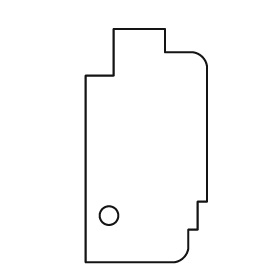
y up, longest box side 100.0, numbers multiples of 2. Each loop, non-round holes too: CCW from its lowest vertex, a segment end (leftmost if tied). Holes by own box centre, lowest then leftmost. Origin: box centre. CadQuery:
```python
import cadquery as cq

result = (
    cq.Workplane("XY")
    .moveTo(-26.0, -50.0)
    .lineTo(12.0, -50.0)
    .threePointArc((16.0, -48.0), (18.0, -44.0))
    .lineTo(18.0, -36.0)
    .lineTo(22.0, -36.0)
    .lineTo(22.0, -24.0)
    .lineTo(26.0, -24.0)
    .lineTo(26.0, 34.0)
    .threePointArc((24.0, 38.0), (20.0, 40.0))
    .lineTo(8.0, 40.0)
    .lineTo(8.0, 50.0)
    .lineTo(-14.0, 50.0)
    .lineTo(-14.0, 30.0)
    .lineTo(-26.0, 30.0)
    .close()
    .moveTo(-16.0, -30.0)
    .circle(4.0)
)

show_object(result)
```